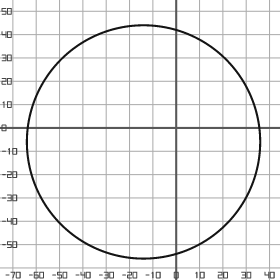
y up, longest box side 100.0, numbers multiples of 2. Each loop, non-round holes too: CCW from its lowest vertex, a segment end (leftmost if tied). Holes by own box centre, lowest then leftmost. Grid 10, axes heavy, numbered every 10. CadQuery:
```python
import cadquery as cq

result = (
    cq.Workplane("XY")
    .moveTo(-14.0, -6.0)
    .circle(50.0)
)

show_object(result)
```